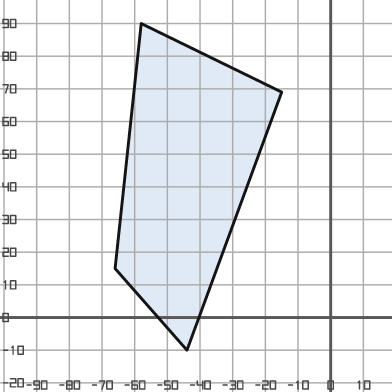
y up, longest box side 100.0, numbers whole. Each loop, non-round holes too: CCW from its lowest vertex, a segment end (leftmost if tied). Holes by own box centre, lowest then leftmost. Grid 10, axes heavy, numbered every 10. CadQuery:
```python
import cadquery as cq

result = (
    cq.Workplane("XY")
    .moveTo(-44.0, -10.0)
    .lineTo(-15.0, 69.0)
    .lineTo(-58.0, 90.0)
    .lineTo(-66.0, 15.0)
    .close()
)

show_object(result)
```